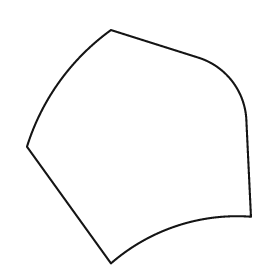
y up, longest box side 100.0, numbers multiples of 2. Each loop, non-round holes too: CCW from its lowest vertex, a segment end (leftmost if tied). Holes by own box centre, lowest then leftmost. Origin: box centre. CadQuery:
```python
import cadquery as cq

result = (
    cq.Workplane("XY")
    .moveTo(-12.0, -50.0)
    .threePointArc((16.0, -34.0), (48.0, -30.0))
    .lineTo(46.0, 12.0)
    .threePointArc((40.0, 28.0), (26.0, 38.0))
    .lineTo(-12.0, 50.0)
    .threePointArc((-34.0, 28.0), (-48.0, 0.0))
    .close()
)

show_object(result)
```